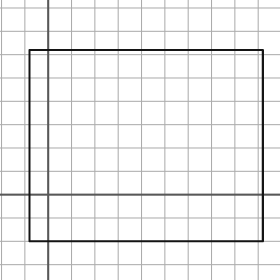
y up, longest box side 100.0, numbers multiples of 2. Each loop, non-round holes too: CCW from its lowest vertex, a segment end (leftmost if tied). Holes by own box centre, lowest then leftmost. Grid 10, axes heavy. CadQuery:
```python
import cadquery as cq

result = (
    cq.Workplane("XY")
    .moveTo(-8.0, -20.0)
    .lineTo(92.0, -20.0)
    .lineTo(92.0, 62.0)
    .lineTo(-8.0, 62.0)
    .close()
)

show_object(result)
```